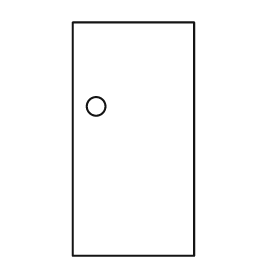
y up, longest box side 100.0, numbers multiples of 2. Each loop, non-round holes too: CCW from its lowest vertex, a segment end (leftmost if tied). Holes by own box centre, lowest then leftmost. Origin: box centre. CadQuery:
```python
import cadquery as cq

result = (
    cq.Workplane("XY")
    .moveTo(-26.0, -50.0)
    .lineTo(26.0, -50.0)
    .lineTo(26.0, 50.0)
    .lineTo(-26.0, 50.0)
    .close()
    .moveTo(-16.0, 14.0)
    .circle(4.0)
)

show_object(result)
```